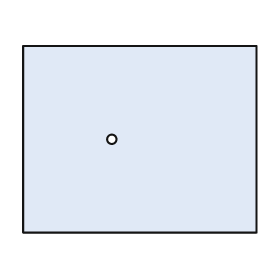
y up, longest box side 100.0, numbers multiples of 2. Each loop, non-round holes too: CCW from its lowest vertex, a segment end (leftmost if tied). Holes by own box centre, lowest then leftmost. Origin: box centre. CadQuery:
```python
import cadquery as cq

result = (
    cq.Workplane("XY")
    .moveTo(-50.0, -40.0)
    .lineTo(50.0, -40.0)
    .lineTo(50.0, 40.0)
    .lineTo(-50.0, 40.0)
    .close()
    .moveTo(-12.0, 0.0)
    .circle(2.0)
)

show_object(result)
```